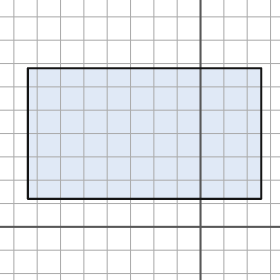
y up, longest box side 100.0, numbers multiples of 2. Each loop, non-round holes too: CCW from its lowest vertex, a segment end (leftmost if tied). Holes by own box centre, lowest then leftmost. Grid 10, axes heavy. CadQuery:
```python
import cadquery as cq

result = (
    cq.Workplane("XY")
    .moveTo(-74.0, 12.0)
    .lineTo(26.0, 12.0)
    .lineTo(26.0, 68.0)
    .lineTo(-74.0, 68.0)
    .close()
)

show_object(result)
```